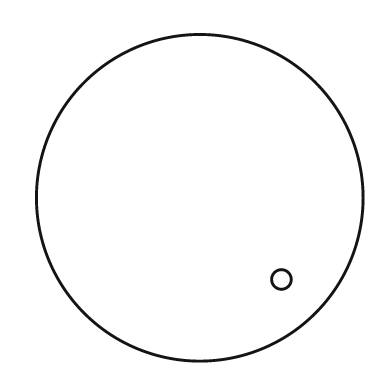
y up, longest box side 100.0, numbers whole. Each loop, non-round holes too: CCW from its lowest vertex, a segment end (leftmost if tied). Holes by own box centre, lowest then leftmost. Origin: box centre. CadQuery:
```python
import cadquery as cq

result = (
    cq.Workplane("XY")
    .moveTo(0.0, 0.0)
    .circle(50.0)
    .moveTo(25.0, -25.0)
    .circle(3.0)
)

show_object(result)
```